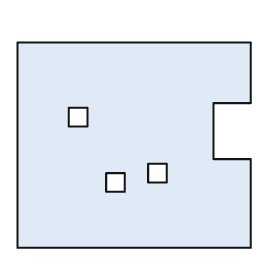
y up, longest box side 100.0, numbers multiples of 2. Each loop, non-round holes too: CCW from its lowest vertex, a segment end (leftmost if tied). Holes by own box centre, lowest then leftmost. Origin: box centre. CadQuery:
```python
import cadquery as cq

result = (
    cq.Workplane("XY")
    .moveTo(-50.0, -44.0)
    .lineTo(50.0, -44.0)
    .lineTo(50.0, -6.0)
    .lineTo(34.0, -6.0)
    .lineTo(34.0, 18.0)
    .lineTo(50.0, 18.0)
    .lineTo(50.0, 44.0)
    .lineTo(-50.0, 44.0)
    .close()
    .moveTo(-12.0, -20.0)
    .lineTo(-4.0, -20.0)
    .lineTo(-4.0, -12.0)
    .lineTo(-12.0, -12.0)
    .close()
    .moveTo(6.0, -16.0)
    .lineTo(14.0, -16.0)
    .lineTo(14.0, -8.0)
    .lineTo(6.0, -8.0)
    .close()
    .moveTo(-28.0, 8.0)
    .lineTo(-20.0, 8.0)
    .lineTo(-20.0, 16.0)
    .lineTo(-28.0, 16.0)
    .close()
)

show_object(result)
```